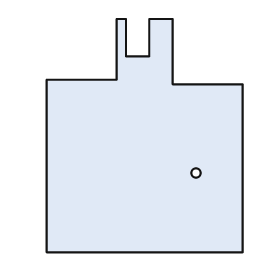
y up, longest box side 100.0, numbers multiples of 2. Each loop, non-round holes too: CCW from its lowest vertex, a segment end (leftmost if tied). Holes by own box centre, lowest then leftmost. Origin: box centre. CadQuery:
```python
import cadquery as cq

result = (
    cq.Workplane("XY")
    .moveTo(-42.0, -50.0)
    .lineTo(42.0, -50.0)
    .lineTo(42.0, 22.0)
    .lineTo(12.0, 22.0)
    .lineTo(12.0, 50.0)
    .lineTo(2.0, 50.0)
    .lineTo(2.0, 34.0)
    .lineTo(-8.0, 34.0)
    .lineTo(-8.0, 50.0)
    .lineTo(-12.0, 50.0)
    .lineTo(-12.0, 24.0)
    .lineTo(-42.0, 24.0)
    .close()
    .moveTo(22.0, -16.0)
    .circle(2.0)
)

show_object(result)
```